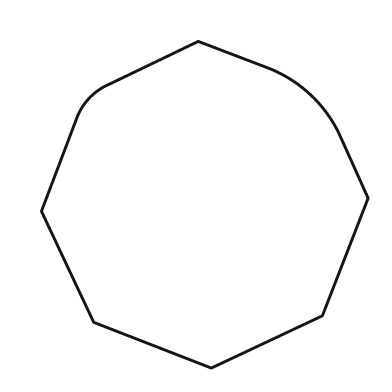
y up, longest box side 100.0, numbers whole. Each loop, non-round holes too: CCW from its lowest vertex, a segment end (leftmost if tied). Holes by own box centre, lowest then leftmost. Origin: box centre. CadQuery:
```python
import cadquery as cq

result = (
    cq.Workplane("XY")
    .moveTo(2.0, -50.0)
    .lineTo(36.0, -34.0)
    .lineTo(50.0, 2.0)
    .lineTo(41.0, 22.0)
    .threePointArc((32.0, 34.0), (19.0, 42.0))
    .lineTo(-2.0, 50.0)
    .lineTo(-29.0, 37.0)
    .threePointArc((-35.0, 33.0), (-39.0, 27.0))
    .lineTo(-50.0, -2.0)
    .lineTo(-34.0, -36.0)
    .close()
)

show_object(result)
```